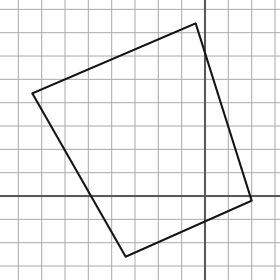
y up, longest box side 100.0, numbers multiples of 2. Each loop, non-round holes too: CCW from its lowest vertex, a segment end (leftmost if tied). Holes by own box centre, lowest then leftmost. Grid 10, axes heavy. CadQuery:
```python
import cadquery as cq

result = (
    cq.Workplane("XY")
    .moveTo(-34.0, -26.0)
    .lineTo(20.0, -2.0)
    .lineTo(-4.0, 74.0)
    .lineTo(-74.0, 44.0)
    .close()
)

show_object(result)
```